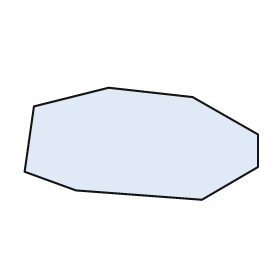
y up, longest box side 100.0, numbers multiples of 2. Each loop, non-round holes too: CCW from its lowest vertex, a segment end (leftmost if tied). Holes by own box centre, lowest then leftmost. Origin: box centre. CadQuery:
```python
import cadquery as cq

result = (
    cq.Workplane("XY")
    .moveTo(26.0, -24.0)
    .lineTo(50.0, -10.0)
    .lineTo(50.0, 4.0)
    .lineTo(22.0, 20.0)
    .lineTo(-14.0, 24.0)
    .lineTo(-46.0, 16.0)
    .lineTo(-50.0, -12.0)
    .lineTo(-28.0, -20.0)
    .close()
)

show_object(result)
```